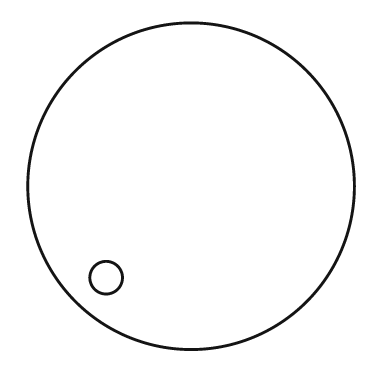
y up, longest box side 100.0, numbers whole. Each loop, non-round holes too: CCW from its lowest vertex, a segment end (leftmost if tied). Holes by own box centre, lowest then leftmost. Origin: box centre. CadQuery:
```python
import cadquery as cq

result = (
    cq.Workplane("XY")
    .moveTo(0.0, 0.0)
    .circle(50.0)
    .moveTo(-26.0, -28.0)
    .circle(5.0)
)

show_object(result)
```